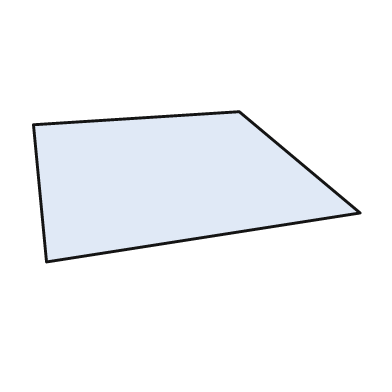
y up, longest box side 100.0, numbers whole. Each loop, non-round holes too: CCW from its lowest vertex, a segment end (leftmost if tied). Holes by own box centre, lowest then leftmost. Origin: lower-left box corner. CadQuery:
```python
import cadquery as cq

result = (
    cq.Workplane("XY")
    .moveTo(4.0, 0.0)
    .lineTo(100.0, 15.0)
    .lineTo(63.0, 46.0)
    .lineTo(0.0, 42.0)
    .close()
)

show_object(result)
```